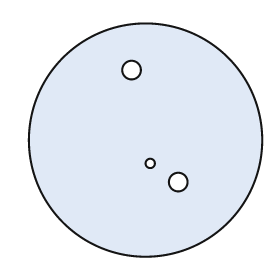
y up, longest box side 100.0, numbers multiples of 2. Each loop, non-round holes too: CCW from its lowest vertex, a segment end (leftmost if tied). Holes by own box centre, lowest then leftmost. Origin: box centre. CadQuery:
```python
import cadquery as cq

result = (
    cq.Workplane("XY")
    .moveTo(0.0, 0.0)
    .circle(50.0)
    .moveTo(14.0, -18.0)
    .circle(4.0)
    .moveTo(2.0, -10.0)
    .circle(2.0)
    .moveTo(-6.0, 30.0)
    .circle(4.0)
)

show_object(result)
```